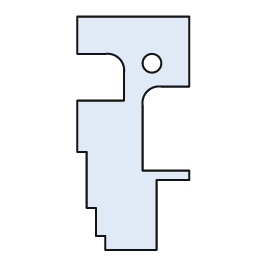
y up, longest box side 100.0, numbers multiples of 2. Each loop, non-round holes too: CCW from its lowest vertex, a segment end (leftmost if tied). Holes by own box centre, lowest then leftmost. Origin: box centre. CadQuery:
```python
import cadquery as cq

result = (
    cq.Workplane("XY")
    .moveTo(-12.0, -50.0)
    .lineTo(10.0, -50.0)
    .lineTo(10.0, -20.0)
    .lineTo(24.0, -20.0)
    .lineTo(24.0, -16.0)
    .lineTo(4.0, -16.0)
    .lineTo(4.0, 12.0)
    .threePointArc((6.0, 18.0), (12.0, 20.0))
    .lineTo(24.0, 20.0)
    .lineTo(24.0, 50.0)
    .lineTo(-24.0, 50.0)
    .lineTo(-24.0, 34.0)
    .lineTo(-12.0, 34.0)
    .threePointArc((-6.0, 32.0), (-4.0, 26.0))
    .lineTo(-4.0, 14.0)
    .lineTo(-24.0, 14.0)
    .lineTo(-24.0, -8.0)
    .lineTo(-20.0, -8.0)
    .lineTo(-20.0, -32.0)
    .lineTo(-16.0, -32.0)
    .lineTo(-16.0, -44.0)
    .lineTo(-12.0, -44.0)
    .close()
    .moveTo(8.0, 30.0)
    .circle(4.0)
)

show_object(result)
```